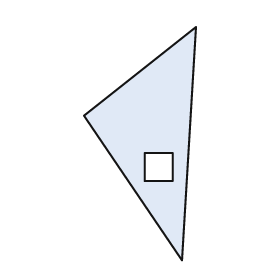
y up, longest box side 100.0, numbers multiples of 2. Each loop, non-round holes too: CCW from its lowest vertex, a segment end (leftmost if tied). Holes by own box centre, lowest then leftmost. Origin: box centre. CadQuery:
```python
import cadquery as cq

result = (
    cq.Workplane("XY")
    .moveTo(18.0, -50.0)
    .lineTo(24.0, 50.0)
    .lineTo(-24.0, 12.0)
    .close()
    .moveTo(2.0, -16.0)
    .lineTo(14.0, -16.0)
    .lineTo(14.0, -4.0)
    .lineTo(2.0, -4.0)
    .close()
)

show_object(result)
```